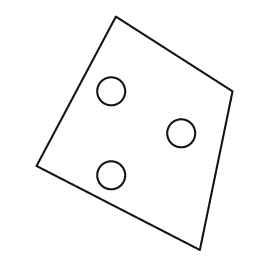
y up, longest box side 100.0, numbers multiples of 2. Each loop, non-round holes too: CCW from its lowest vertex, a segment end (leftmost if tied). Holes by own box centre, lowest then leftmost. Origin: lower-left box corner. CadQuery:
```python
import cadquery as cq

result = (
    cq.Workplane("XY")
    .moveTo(70.0, 0.0)
    .lineTo(84.0, 68.0)
    .lineTo(34.0, 100.0)
    .lineTo(0.0, 36.0)
    .close()
    .moveTo(32.0, 32.0)
    .circle(6.0)
    .moveTo(62.0, 50.0)
    .circle(6.0)
    .moveTo(32.0, 68.0)
    .circle(6.0)
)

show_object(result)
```